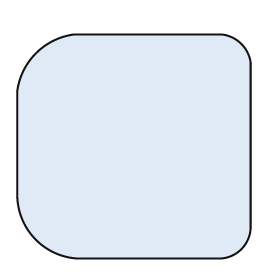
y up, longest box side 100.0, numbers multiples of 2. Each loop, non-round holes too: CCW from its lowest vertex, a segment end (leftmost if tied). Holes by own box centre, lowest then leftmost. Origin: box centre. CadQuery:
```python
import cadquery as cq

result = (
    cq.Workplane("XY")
    .moveTo(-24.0, -48.0)
    .lineTo(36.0, -48.0)
    .threePointArc((46.0, -44.0), (50.0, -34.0))
    .lineTo(50.0, 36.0)
    .threePointArc((46.0, 44.0), (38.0, 48.0))
    .lineTo(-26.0, 48.0)
    .threePointArc((-42.0, 40.0), (-50.0, 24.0))
    .lineTo(-50.0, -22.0)
    .threePointArc((-42.0, -40.0), (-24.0, -48.0))
    .close()
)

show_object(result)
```